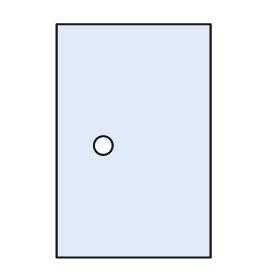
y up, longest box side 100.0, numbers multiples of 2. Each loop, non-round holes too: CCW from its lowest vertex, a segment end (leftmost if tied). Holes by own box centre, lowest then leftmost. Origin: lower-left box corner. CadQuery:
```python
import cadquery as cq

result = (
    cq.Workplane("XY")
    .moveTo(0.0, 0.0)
    .lineTo(66.0, 0.0)
    .lineTo(66.0, 100.0)
    .lineTo(0.0, 100.0)
    .close()
    .moveTo(20.0, 48.0)
    .circle(4.0)
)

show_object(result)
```